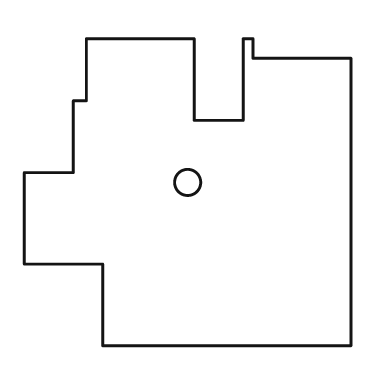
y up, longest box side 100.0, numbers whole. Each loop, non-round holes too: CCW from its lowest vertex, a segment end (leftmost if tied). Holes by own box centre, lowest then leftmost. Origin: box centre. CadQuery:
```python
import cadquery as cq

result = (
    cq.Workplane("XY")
    .moveTo(-26.0, -47.0)
    .lineTo(50.0, -47.0)
    .lineTo(50.0, 41.0)
    .lineTo(20.0, 41.0)
    .lineTo(20.0, 47.0)
    .lineTo(17.0, 47.0)
    .lineTo(17.0, 22.0)
    .lineTo(2.0, 22.0)
    .lineTo(2.0, 47.0)
    .lineTo(-31.0, 47.0)
    .lineTo(-31.0, 28.0)
    .lineTo(-35.0, 28.0)
    .lineTo(-35.0, 6.0)
    .lineTo(-50.0, 6.0)
    .lineTo(-50.0, -22.0)
    .lineTo(-26.0, -22.0)
    .close()
    .moveTo(0.0, 3.0)
    .circle(4.0)
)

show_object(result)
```